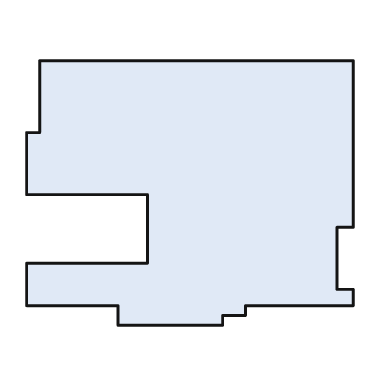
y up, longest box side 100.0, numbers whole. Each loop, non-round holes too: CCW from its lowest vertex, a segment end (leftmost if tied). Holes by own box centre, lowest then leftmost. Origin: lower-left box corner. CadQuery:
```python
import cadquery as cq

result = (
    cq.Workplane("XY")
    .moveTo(28.0, 0.0)
    .lineTo(60.0, 0.0)
    .lineTo(60.0, 3.0)
    .lineTo(67.0, 3.0)
    .lineTo(67.0, 6.0)
    .lineTo(100.0, 6.0)
    .lineTo(100.0, 11.0)
    .lineTo(95.0, 11.0)
    .lineTo(95.0, 30.0)
    .lineTo(100.0, 30.0)
    .lineTo(100.0, 81.0)
    .lineTo(4.0, 81.0)
    .lineTo(4.0, 59.0)
    .lineTo(0.0, 59.0)
    .lineTo(0.0, 40.0)
    .lineTo(37.0, 40.0)
    .lineTo(37.0, 19.0)
    .lineTo(0.0, 19.0)
    .lineTo(0.0, 6.0)
    .lineTo(28.0, 6.0)
    .close()
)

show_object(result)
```